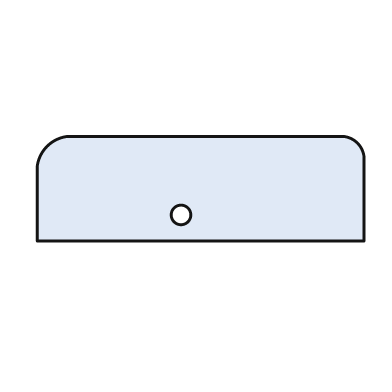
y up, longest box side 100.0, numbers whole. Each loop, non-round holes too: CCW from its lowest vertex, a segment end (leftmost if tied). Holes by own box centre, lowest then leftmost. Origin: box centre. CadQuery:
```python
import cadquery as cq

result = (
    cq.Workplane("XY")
    .moveTo(-50.0, -16.0)
    .lineTo(50.0, -16.0)
    .lineTo(50.0, 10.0)
    .threePointArc((48.0, 14.0), (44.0, 16.0))
    .lineTo(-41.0, 16.0)
    .threePointArc((-47.0, 13.0), (-50.0, 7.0))
    .close()
    .moveTo(-6.0, -8.0)
    .circle(3.0)
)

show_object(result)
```